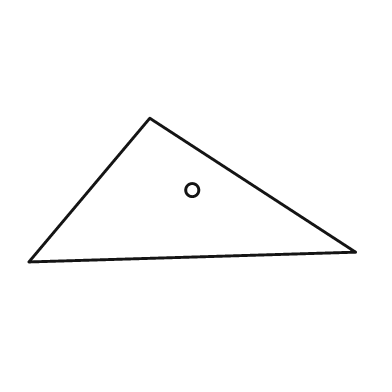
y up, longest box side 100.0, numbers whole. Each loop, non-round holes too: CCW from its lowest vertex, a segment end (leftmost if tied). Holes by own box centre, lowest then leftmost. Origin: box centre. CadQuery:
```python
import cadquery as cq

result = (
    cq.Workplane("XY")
    .moveTo(-50.0, -22.0)
    .lineTo(50.0, -19.0)
    .lineTo(-13.0, 22.0)
    .close()
    .moveTo(0.0, 0.0)
    .circle(2.0)
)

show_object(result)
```